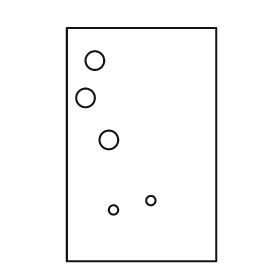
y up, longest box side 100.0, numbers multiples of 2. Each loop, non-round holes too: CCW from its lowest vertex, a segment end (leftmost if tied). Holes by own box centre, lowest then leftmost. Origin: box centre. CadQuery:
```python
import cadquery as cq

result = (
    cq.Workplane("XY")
    .moveTo(-32.0, -50.0)
    .lineTo(32.0, -50.0)
    .lineTo(32.0, 50.0)
    .lineTo(-32.0, 50.0)
    .close()
    .moveTo(-12.0, -28.0)
    .circle(2.0)
    .moveTo(4.0, -24.0)
    .circle(2.0)
    .moveTo(-14.0, 2.0)
    .circle(4.0)
    .moveTo(-24.0, 20.0)
    .circle(4.0)
    .moveTo(-20.0, 36.0)
    .circle(4.0)
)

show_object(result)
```